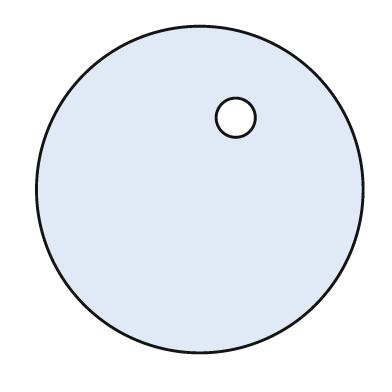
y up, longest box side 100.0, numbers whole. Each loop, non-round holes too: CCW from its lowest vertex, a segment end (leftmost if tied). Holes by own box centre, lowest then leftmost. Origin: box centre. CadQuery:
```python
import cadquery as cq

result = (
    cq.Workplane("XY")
    .moveTo(0.0, 0.0)
    .circle(50.0)
    .moveTo(11.0, 22.0)
    .circle(6.0)
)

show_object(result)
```